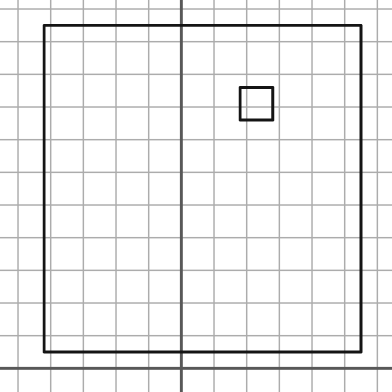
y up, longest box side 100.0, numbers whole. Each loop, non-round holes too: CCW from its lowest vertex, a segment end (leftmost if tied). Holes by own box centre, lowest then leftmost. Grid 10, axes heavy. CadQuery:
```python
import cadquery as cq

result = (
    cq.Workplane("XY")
    .moveTo(-42.0, 5.0)
    .lineTo(55.0, 5.0)
    .lineTo(55.0, 105.0)
    .lineTo(-42.0, 105.0)
    .close()
    .moveTo(18.0, 76.0)
    .lineTo(28.0, 76.0)
    .lineTo(28.0, 86.0)
    .lineTo(18.0, 86.0)
    .close()
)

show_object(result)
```